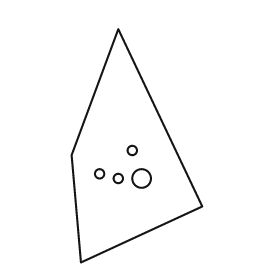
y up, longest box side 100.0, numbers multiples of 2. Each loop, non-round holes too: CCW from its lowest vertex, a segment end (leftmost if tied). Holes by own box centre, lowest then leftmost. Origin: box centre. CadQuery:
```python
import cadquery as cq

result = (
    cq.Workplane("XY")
    .moveTo(-24.0, -50.0)
    .lineTo(28.0, -26.0)
    .lineTo(-8.0, 50.0)
    .lineTo(-28.0, -4.0)
    .close()
    .moveTo(-8.0, -14.0)
    .circle(2.0)
    .moveTo(2.0, -14.0)
    .circle(4.0)
    .moveTo(-16.0, -12.0)
    .circle(2.0)
    .moveTo(-2.0, -2.0)
    .circle(2.0)
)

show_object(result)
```